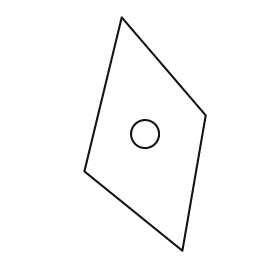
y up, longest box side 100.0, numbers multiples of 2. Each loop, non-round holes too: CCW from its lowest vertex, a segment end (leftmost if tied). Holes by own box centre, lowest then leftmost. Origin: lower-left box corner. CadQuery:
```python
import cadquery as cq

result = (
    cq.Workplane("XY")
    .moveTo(42.0, 0.0)
    .lineTo(52.0, 58.0)
    .lineTo(16.0, 100.0)
    .lineTo(0.0, 34.0)
    .close()
    .moveTo(26.0, 50.0)
    .circle(6.0)
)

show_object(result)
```